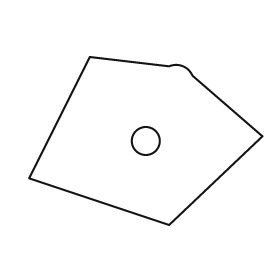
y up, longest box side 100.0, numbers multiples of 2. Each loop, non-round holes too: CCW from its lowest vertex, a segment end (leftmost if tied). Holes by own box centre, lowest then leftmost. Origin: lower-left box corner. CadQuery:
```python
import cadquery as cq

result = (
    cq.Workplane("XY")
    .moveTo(60.0, 0.0)
    .lineTo(100.0, 38.0)
    .lineTo(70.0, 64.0)
    .threePointArc((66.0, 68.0), (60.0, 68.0))
    .lineTo(26.0, 72.0)
    .lineTo(0.0, 20.0)
    .close()
    .moveTo(50.0, 36.0)
    .circle(6.0)
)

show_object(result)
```